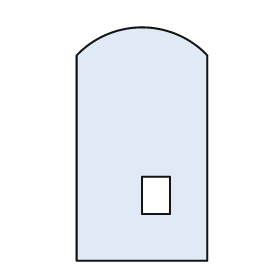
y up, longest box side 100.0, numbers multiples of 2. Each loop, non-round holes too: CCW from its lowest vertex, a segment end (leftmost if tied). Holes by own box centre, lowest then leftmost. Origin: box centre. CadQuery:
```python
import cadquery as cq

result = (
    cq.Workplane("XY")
    .moveTo(-28.0, -50.0)
    .lineTo(28.0, -50.0)
    .lineTo(28.0, 38.0)
    .threePointArc((0.0, 50.0), (-28.0, 38.0))
    .close()
    .moveTo(0.0, -30.0)
    .lineTo(12.0, -30.0)
    .lineTo(12.0, -14.0)
    .lineTo(0.0, -14.0)
    .close()
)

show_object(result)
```